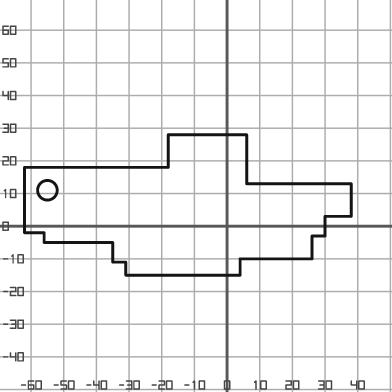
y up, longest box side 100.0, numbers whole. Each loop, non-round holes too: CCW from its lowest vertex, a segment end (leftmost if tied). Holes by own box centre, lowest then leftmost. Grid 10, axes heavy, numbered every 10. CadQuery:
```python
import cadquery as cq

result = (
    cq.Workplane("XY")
    .moveTo(-31.0, -15.0)
    .lineTo(4.0, -15.0)
    .lineTo(4.0, -10.0)
    .lineTo(26.0, -10.0)
    .lineTo(26.0, -3.0)
    .lineTo(30.0, -3.0)
    .lineTo(30.0, 3.0)
    .lineTo(38.0, 3.0)
    .lineTo(38.0, 13.0)
    .lineTo(6.0, 13.0)
    .lineTo(6.0, 28.0)
    .lineTo(-18.0, 28.0)
    .lineTo(-18.0, 18.0)
    .lineTo(-62.0, 18.0)
    .lineTo(-62.0, -2.0)
    .lineTo(-56.0, -2.0)
    .lineTo(-56.0, -5.0)
    .lineTo(-35.0, -5.0)
    .lineTo(-35.0, -11.0)
    .lineTo(-31.0, -11.0)
    .close()
    .moveTo(-55.0, 11.0)
    .circle(3.0)
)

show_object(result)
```